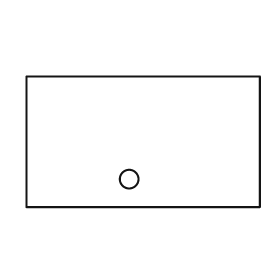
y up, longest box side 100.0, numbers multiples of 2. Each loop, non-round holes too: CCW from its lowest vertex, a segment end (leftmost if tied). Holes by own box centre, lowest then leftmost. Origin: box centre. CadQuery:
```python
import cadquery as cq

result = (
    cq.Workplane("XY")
    .moveTo(-50.0, -28.0)
    .lineTo(50.0, -28.0)
    .lineTo(50.0, 28.0)
    .lineTo(-50.0, 28.0)
    .close()
    .moveTo(-6.0, -16.0)
    .circle(4.0)
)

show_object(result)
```